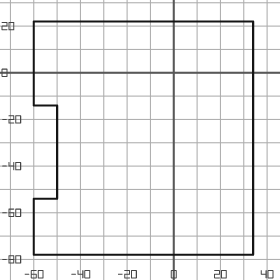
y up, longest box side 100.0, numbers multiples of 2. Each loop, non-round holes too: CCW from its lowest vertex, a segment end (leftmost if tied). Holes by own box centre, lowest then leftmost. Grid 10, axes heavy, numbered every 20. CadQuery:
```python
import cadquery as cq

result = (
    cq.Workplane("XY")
    .moveTo(-60.0, -78.0)
    .lineTo(34.0, -78.0)
    .lineTo(34.0, 22.0)
    .lineTo(-60.0, 22.0)
    .lineTo(-60.0, -14.0)
    .lineTo(-50.0, -14.0)
    .lineTo(-50.0, -54.0)
    .lineTo(-60.0, -54.0)
    .close()
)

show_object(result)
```